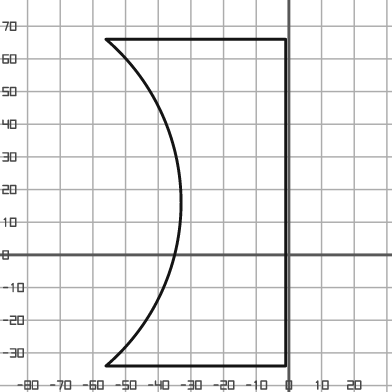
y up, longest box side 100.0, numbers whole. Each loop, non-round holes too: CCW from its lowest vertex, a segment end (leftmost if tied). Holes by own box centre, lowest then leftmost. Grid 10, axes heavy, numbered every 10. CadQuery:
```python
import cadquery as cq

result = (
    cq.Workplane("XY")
    .moveTo(-56.0, -34.0)
    .lineTo(-1.0, -34.0)
    .lineTo(-1.0, 66.0)
    .lineTo(-56.0, 66.0)
    .threePointArc((-33.0, 16.0), (-56.0, -34.0))
    .close()
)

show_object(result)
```